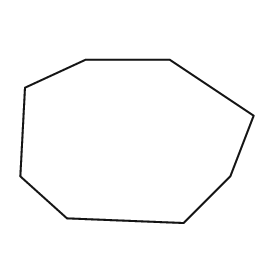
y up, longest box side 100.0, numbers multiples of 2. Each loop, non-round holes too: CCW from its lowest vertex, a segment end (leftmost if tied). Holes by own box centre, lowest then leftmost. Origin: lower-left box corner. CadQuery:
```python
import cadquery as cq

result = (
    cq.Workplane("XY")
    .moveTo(70.0, 0.0)
    .lineTo(90.0, 20.0)
    .lineTo(100.0, 46.0)
    .lineTo(64.0, 70.0)
    .lineTo(28.0, 70.0)
    .lineTo(2.0, 58.0)
    .lineTo(0.0, 20.0)
    .lineTo(20.0, 2.0)
    .close()
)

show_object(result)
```